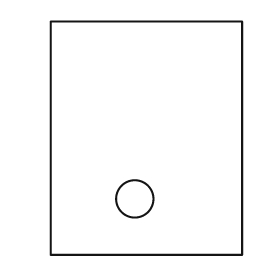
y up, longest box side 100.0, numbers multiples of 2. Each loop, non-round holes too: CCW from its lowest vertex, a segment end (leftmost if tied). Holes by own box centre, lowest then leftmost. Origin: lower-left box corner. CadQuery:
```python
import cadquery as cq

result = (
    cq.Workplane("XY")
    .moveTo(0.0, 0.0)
    .lineTo(82.0, 0.0)
    .lineTo(82.0, 100.0)
    .lineTo(0.0, 100.0)
    .close()
    .moveTo(36.0, 24.0)
    .circle(8.0)
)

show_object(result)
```